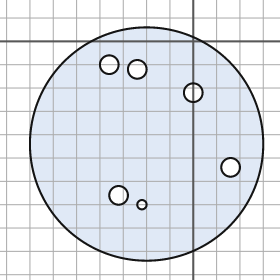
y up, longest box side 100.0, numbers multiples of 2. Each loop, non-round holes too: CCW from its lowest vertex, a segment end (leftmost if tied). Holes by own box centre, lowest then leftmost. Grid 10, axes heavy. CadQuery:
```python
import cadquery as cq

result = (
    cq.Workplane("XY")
    .moveTo(-20.0, -44.0)
    .circle(50.0)
    .moveTo(-22.0, -70.0)
    .circle(2.0)
    .moveTo(-32.0, -66.0)
    .circle(4.0)
    .moveTo(16.0, -54.0)
    .circle(4.0)
    .moveTo(0.0, -22.0)
    .circle(4.0)
    .moveTo(-24.0, -12.0)
    .circle(4.0)
    .moveTo(-36.0, -10.0)
    .circle(4.0)
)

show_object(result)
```